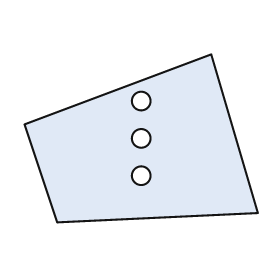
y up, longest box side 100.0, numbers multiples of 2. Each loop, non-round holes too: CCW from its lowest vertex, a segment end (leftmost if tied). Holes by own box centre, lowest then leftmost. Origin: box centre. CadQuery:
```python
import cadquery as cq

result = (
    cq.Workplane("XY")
    .moveTo(-36.0, -36.0)
    .lineTo(50.0, -32.0)
    .lineTo(30.0, 36.0)
    .lineTo(-50.0, 6.0)
    .close()
    .moveTo(0.0, -16.0)
    .circle(4.0)
    .moveTo(0.0, 0.0)
    .circle(4.0)
    .moveTo(0.0, 16.0)
    .circle(4.0)
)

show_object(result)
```